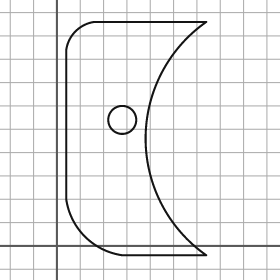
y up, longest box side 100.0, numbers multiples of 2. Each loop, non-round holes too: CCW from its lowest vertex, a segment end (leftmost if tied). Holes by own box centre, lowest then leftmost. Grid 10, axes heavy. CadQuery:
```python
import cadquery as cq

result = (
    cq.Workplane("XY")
    .moveTo(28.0, -4.0)
    .lineTo(64.0, -4.0)
    .threePointArc((38.0, 46.0), (64.0, 96.0))
    .lineTo(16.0, 96.0)
    .threePointArc((8.0, 92.0), (4.0, 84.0))
    .lineTo(4.0, 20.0)
    .threePointArc((12.0, 4.0), (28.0, -4.0))
    .close()
    .moveTo(28.0, 54.0)
    .circle(6.0)
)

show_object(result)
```